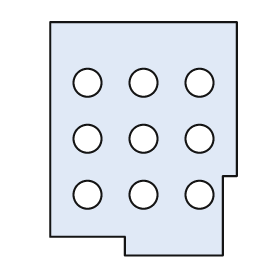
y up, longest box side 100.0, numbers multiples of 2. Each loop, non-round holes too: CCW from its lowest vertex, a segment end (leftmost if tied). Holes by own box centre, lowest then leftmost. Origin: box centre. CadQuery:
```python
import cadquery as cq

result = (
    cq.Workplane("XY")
    .moveTo(-8.0, -50.0)
    .lineTo(34.0, -50.0)
    .lineTo(34.0, -16.0)
    .lineTo(40.0, -16.0)
    .lineTo(40.0, 50.0)
    .lineTo(-40.0, 50.0)
    .lineTo(-40.0, -42.0)
    .lineTo(-8.0, -42.0)
    .close()
    .moveTo(-24.0, -24.0)
    .circle(6.0)
    .moveTo(0.0, -24.0)
    .circle(6.0)
    .moveTo(24.0, -24.0)
    .circle(6.0)
    .moveTo(-24.0, 0.0)
    .circle(6.0)
    .moveTo(0.0, 0.0)
    .circle(6.0)
    .moveTo(24.0, 0.0)
    .circle(6.0)
    .moveTo(-24.0, 24.0)
    .circle(6.0)
    .moveTo(0.0, 24.0)
    .circle(6.0)
    .moveTo(24.0, 24.0)
    .circle(6.0)
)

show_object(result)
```